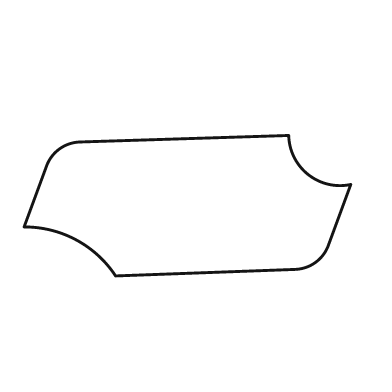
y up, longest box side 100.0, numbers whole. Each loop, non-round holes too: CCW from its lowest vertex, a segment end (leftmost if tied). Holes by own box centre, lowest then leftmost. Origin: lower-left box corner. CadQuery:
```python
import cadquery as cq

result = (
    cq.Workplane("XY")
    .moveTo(28.0, 0.0)
    .lineTo(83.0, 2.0)
    .threePointArc((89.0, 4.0), (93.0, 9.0))
    .lineTo(100.0, 28.0)
    .threePointArc((87.0, 31.0), (81.0, 43.0))
    .lineTo(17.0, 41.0)
    .threePointArc((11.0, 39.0), (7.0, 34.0))
    .lineTo(0.0, 15.0)
    .threePointArc((16.0, 11.0), (28.0, 0.0))
    .close()
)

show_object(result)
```